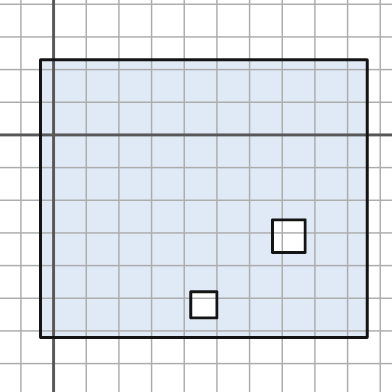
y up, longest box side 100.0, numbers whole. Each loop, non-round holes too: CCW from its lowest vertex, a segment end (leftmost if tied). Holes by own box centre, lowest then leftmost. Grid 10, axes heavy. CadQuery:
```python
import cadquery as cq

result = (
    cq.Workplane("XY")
    .moveTo(-4.0, -62.0)
    .lineTo(96.0, -62.0)
    .lineTo(96.0, 23.0)
    .lineTo(-4.0, 23.0)
    .close()
    .moveTo(42.0, -56.0)
    .lineTo(50.0, -56.0)
    .lineTo(50.0, -48.0)
    .lineTo(42.0, -48.0)
    .close()
    .moveTo(67.0, -36.0)
    .lineTo(77.0, -36.0)
    .lineTo(77.0, -26.0)
    .lineTo(67.0, -26.0)
    .close()
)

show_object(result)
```